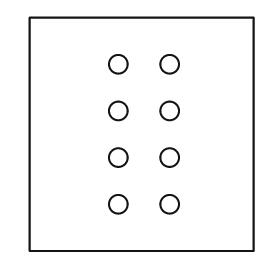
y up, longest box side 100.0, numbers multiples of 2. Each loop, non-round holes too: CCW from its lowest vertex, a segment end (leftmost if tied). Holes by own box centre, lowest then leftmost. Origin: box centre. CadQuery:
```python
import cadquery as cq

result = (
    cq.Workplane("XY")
    .moveTo(-48.0, -50.0)
    .lineTo(48.0, -50.0)
    .lineTo(48.0, 50.0)
    .lineTo(-48.0, 50.0)
    .close()
    .moveTo(-10.0, -30.0)
    .circle(4.0)
    .moveTo(12.0, -30.0)
    .circle(4.0)
    .moveTo(-10.0, -10.0)
    .circle(4.0)
    .moveTo(12.0, -10.0)
    .circle(4.0)
    .moveTo(-10.0, 10.0)
    .circle(4.0)
    .moveTo(12.0, 10.0)
    .circle(4.0)
    .moveTo(-10.0, 30.0)
    .circle(4.0)
    .moveTo(12.0, 30.0)
    .circle(4.0)
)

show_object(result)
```